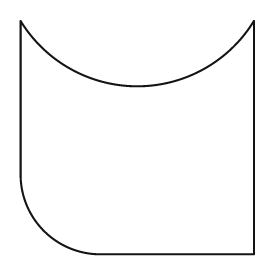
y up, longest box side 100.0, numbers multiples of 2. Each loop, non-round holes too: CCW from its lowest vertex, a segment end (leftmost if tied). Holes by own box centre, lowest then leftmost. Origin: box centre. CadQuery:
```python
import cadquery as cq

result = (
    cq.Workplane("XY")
    .moveTo(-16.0, -50.0)
    .lineTo(50.0, -50.0)
    .lineTo(50.0, 50.0)
    .threePointArc((0.0, 22.0), (-50.0, 50.0))
    .lineTo(-50.0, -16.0)
    .threePointArc((-40.0, -40.0), (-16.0, -50.0))
    .close()
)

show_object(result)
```